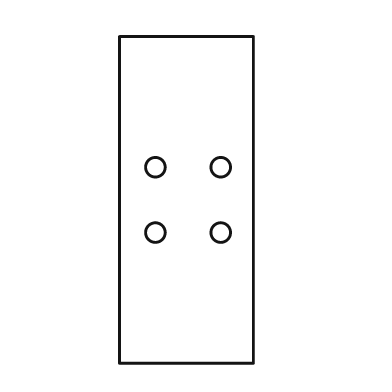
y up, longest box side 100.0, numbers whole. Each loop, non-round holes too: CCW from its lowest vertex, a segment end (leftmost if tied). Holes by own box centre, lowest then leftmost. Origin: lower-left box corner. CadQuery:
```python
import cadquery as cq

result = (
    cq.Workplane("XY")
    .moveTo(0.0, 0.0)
    .lineTo(41.0, 0.0)
    .lineTo(41.0, 100.0)
    .lineTo(0.0, 100.0)
    .close()
    .moveTo(11.0, 40.0)
    .circle(3.0)
    .moveTo(31.0, 40.0)
    .circle(3.0)
    .moveTo(11.0, 60.0)
    .circle(3.0)
    .moveTo(31.0, 60.0)
    .circle(3.0)
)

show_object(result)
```